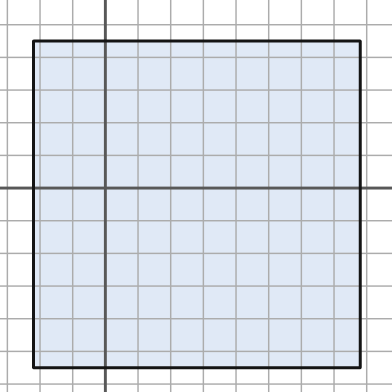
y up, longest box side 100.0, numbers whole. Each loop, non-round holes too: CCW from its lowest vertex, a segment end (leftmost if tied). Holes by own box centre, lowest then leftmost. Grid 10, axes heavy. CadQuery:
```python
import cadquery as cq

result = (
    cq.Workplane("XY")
    .moveTo(-22.0, -55.0)
    .lineTo(78.0, -55.0)
    .lineTo(78.0, 45.0)
    .lineTo(-22.0, 45.0)
    .close()
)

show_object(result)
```